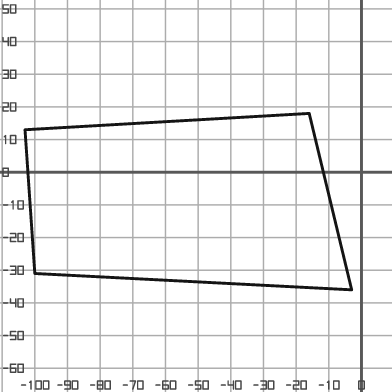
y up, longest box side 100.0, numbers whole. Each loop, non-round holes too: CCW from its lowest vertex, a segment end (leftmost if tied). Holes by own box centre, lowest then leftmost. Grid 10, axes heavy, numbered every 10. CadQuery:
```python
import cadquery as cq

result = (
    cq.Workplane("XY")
    .moveTo(-3.0, -36.0)
    .lineTo(-16.0, 18.0)
    .lineTo(-103.0, 13.0)
    .lineTo(-100.0, -31.0)
    .close()
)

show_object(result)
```